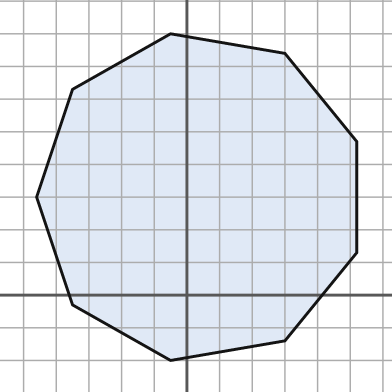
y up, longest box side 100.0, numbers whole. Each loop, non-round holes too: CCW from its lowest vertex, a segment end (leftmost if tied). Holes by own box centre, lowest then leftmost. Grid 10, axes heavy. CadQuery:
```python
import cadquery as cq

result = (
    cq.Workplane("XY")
    .moveTo(-5.0, -20.0)
    .lineTo(30.0, -14.0)
    .lineTo(52.0, 13.0)
    .lineTo(52.0, 47.0)
    .lineTo(30.0, 74.0)
    .lineTo(-5.0, 80.0)
    .lineTo(-35.0, 63.0)
    .lineTo(-46.0, 30.0)
    .lineTo(-35.0, -3.0)
    .close()
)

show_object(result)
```